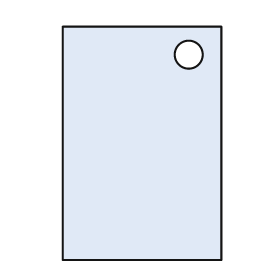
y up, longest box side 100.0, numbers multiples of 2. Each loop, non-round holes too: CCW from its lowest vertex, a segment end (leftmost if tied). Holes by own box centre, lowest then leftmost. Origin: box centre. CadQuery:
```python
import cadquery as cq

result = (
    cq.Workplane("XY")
    .moveTo(-34.0, -50.0)
    .lineTo(34.0, -50.0)
    .lineTo(34.0, 50.0)
    .lineTo(-34.0, 50.0)
    .close()
    .moveTo(20.0, 38.0)
    .circle(6.0)
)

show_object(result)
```